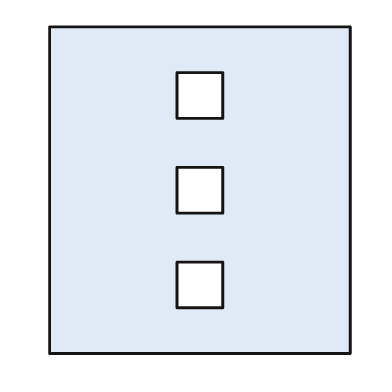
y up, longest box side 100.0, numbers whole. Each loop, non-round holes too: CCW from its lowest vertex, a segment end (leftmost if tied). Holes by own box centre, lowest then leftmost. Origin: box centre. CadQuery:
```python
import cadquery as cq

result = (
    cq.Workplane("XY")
    .moveTo(-46.0, -50.0)
    .lineTo(46.0, -50.0)
    .lineTo(46.0, 50.0)
    .lineTo(-46.0, 50.0)
    .close()
    .moveTo(-7.0, -36.0)
    .lineTo(7.0, -36.0)
    .lineTo(7.0, -22.0)
    .lineTo(-7.0, -22.0)
    .close()
    .moveTo(-7.0, -7.0)
    .lineTo(7.0, -7.0)
    .lineTo(7.0, 7.0)
    .lineTo(-7.0, 7.0)
    .close()
    .moveTo(-7.0, 22.0)
    .lineTo(7.0, 22.0)
    .lineTo(7.0, 36.0)
    .lineTo(-7.0, 36.0)
    .close()
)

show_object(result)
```